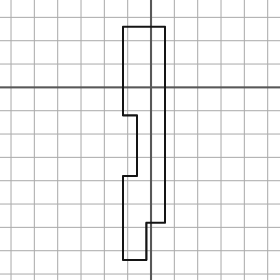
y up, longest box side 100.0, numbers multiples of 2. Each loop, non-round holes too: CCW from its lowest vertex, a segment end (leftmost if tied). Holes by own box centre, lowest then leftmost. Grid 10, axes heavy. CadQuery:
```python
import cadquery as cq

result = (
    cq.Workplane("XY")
    .moveTo(-12.0, -74.0)
    .lineTo(-2.0, -74.0)
    .lineTo(-2.0, -58.0)
    .lineTo(6.0, -58.0)
    .lineTo(6.0, 26.0)
    .lineTo(-12.0, 26.0)
    .lineTo(-12.0, -12.0)
    .lineTo(-6.0, -12.0)
    .lineTo(-6.0, -38.0)
    .lineTo(-12.0, -38.0)
    .close()
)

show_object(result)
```